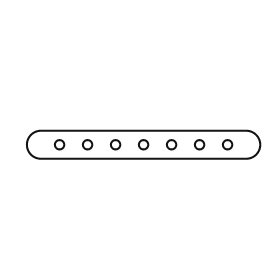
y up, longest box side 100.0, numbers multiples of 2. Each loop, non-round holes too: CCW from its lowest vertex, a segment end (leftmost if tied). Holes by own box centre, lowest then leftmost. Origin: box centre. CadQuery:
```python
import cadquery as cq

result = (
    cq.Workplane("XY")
    .moveTo(-44.0, -6.0)
    .lineTo(44.0, -6.0)
    .threePointArc((50.0, 0.0), (44.0, 6.0))
    .lineTo(-44.0, 6.0)
    .threePointArc((-50.0, 0.0), (-44.0, -6.0))
    .close()
    .moveTo(-36.0, 0.0)
    .circle(2.0)
    .moveTo(-24.0, 0.0)
    .circle(2.0)
    .moveTo(-12.0, 0.0)
    .circle(2.0)
    .moveTo(0.0, 0.0)
    .circle(2.0)
    .moveTo(12.0, 0.0)
    .circle(2.0)
    .moveTo(24.0, 0.0)
    .circle(2.0)
    .moveTo(36.0, 0.0)
    .circle(2.0)
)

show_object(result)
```